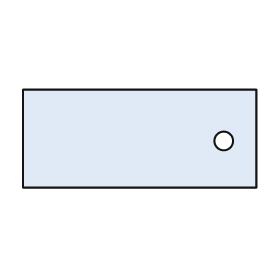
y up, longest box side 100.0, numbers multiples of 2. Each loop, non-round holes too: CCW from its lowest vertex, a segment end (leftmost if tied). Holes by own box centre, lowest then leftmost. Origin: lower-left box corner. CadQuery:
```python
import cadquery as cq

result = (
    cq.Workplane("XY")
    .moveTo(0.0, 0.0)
    .lineTo(100.0, 0.0)
    .lineTo(100.0, 42.0)
    .lineTo(0.0, 42.0)
    .close()
    .moveTo(86.0, 20.0)
    .circle(4.0)
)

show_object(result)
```